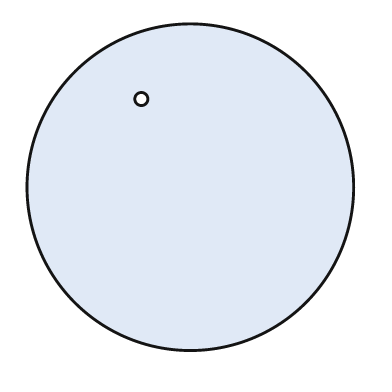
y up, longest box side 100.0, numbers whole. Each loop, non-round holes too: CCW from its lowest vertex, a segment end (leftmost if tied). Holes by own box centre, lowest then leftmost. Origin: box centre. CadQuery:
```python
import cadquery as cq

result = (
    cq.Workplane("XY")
    .moveTo(0.0, 0.0)
    .circle(50.0)
    .moveTo(-15.0, 27.0)
    .circle(2.0)
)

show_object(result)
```